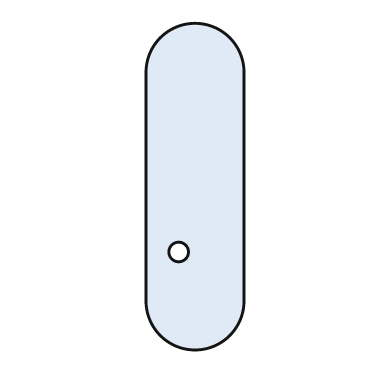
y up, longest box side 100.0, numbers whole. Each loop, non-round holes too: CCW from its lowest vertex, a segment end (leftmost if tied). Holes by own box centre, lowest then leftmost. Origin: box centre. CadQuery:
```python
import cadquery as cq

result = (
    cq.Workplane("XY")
    .moveTo(-15.0, -35.0)
    .threePointArc((0.0, -50.0), (15.0, -35.0))
    .lineTo(15.0, 35.0)
    .threePointArc((0.0, 50.0), (-15.0, 35.0))
    .close()
    .moveTo(-5.0, -20.0)
    .circle(3.0)
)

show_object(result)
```